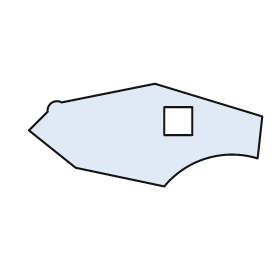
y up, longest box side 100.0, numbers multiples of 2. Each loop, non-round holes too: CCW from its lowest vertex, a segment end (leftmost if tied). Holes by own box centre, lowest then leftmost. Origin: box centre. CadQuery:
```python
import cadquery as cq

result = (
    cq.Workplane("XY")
    .moveTo(8.0, -22.0)
    .threePointArc((26.0, -10.0), (48.0, -10.0))
    .lineTo(50.0, 8.0)
    .lineTo(4.0, 22.0)
    .lineTo(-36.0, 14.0)
    .threePointArc((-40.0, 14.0), (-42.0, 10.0))
    .lineTo(-50.0, 2.0)
    .lineTo(-30.0, -14.0)
    .close()
    .moveTo(8.0, 0.0)
    .lineTo(20.0, 0.0)
    .lineTo(20.0, 12.0)
    .lineTo(8.0, 12.0)
    .close()
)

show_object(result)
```